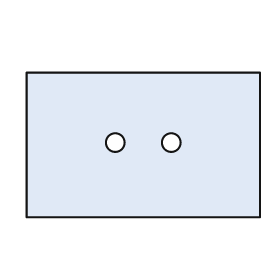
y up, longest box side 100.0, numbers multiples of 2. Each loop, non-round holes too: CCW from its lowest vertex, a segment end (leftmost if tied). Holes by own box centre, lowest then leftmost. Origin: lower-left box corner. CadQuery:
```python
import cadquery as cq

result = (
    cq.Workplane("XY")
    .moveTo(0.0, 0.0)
    .lineTo(100.0, 0.0)
    .lineTo(100.0, 62.0)
    .lineTo(0.0, 62.0)
    .close()
    .moveTo(38.0, 32.0)
    .circle(4.0)
    .moveTo(62.0, 32.0)
    .circle(4.0)
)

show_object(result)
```